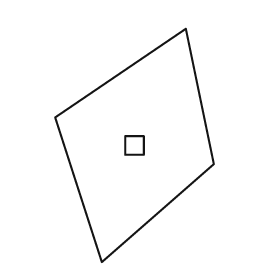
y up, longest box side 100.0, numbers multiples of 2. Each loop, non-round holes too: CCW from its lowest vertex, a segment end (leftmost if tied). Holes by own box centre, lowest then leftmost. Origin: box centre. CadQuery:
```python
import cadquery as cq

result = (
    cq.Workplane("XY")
    .moveTo(-14.0, -50.0)
    .lineTo(34.0, -8.0)
    .lineTo(22.0, 50.0)
    .lineTo(-34.0, 12.0)
    .close()
    .moveTo(-4.0, -4.0)
    .lineTo(4.0, -4.0)
    .lineTo(4.0, 4.0)
    .lineTo(-4.0, 4.0)
    .close()
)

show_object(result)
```